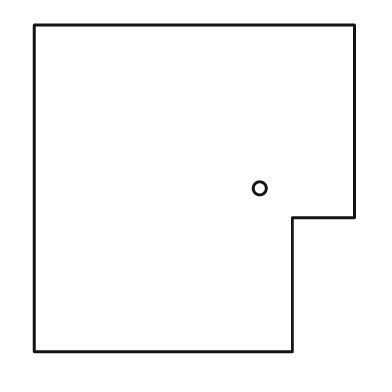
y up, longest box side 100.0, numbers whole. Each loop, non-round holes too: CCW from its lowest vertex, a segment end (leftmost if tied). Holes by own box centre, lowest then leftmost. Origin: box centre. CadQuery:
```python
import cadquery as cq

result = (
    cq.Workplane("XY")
    .moveTo(-49.0, -50.0)
    .lineTo(30.0, -50.0)
    .lineTo(30.0, -9.0)
    .lineTo(49.0, -9.0)
    .lineTo(49.0, 50.0)
    .lineTo(-49.0, 50.0)
    .close()
    .moveTo(20.0, 0.0)
    .circle(2.0)
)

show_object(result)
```